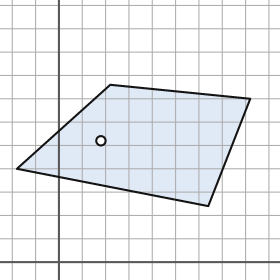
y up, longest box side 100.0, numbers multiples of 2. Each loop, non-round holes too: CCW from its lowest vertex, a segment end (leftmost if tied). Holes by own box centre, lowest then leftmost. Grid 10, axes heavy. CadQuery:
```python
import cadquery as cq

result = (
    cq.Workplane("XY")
    .moveTo(64.0, 24.0)
    .lineTo(82.0, 70.0)
    .lineTo(22.0, 76.0)
    .lineTo(-18.0, 40.0)
    .close()
    .moveTo(18.0, 52.0)
    .circle(2.0)
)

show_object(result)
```